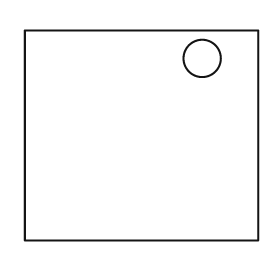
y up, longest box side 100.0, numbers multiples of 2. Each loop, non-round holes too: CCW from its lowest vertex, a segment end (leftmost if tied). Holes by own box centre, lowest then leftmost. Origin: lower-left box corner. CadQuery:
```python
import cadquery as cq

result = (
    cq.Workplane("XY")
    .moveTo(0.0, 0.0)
    .lineTo(100.0, 0.0)
    .lineTo(100.0, 90.0)
    .lineTo(0.0, 90.0)
    .close()
    .moveTo(76.0, 78.0)
    .circle(8.0)
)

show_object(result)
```